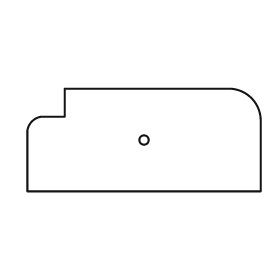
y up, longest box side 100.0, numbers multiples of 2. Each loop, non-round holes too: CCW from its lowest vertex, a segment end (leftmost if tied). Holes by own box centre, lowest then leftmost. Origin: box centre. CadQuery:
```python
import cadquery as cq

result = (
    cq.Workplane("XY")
    .moveTo(-50.0, -22.0)
    .lineTo(50.0, -22.0)
    .lineTo(50.0, 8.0)
    .threePointArc((46.0, 18.0), (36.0, 22.0))
    .lineTo(-34.0, 22.0)
    .lineTo(-34.0, 10.0)
    .lineTo(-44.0, 10.0)
    .threePointArc((-48.0, 8.0), (-50.0, 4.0))
    .close()
    .moveTo(0.0, 0.0)
    .circle(2.0)
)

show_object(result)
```